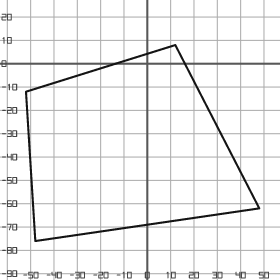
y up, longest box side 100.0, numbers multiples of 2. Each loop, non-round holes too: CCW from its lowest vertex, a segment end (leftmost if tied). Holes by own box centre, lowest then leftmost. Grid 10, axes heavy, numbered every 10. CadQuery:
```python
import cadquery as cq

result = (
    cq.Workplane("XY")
    .moveTo(-48.0, -76.0)
    .lineTo(48.0, -62.0)
    .lineTo(12.0, 8.0)
    .lineTo(-52.0, -12.0)
    .close()
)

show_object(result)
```